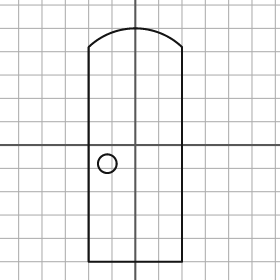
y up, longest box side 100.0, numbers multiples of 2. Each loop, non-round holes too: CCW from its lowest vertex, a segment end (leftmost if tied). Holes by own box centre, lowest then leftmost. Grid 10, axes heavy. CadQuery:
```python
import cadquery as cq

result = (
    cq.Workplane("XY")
    .moveTo(-20.0, -50.0)
    .lineTo(20.0, -50.0)
    .lineTo(20.0, 42.0)
    .threePointArc((0.0, 50.0), (-20.0, 42.0))
    .close()
    .moveTo(-12.0, -8.0)
    .circle(4.0)
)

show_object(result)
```